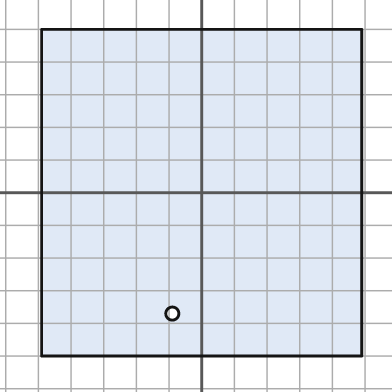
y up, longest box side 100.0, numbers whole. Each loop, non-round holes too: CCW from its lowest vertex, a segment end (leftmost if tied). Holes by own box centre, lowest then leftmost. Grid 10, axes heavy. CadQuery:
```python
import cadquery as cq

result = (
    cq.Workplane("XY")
    .moveTo(-49.0, -50.0)
    .lineTo(49.0, -50.0)
    .lineTo(49.0, 50.0)
    .lineTo(-49.0, 50.0)
    .close()
    .moveTo(-9.0, -37.0)
    .circle(2.0)
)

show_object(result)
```